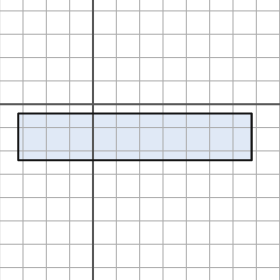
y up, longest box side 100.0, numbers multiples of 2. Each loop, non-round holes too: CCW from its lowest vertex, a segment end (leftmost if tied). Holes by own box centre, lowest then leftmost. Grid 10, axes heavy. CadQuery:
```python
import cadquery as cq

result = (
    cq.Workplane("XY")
    .moveTo(-32.0, -24.0)
    .lineTo(68.0, -24.0)
    .lineTo(68.0, -4.0)
    .lineTo(-32.0, -4.0)
    .close()
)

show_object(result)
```